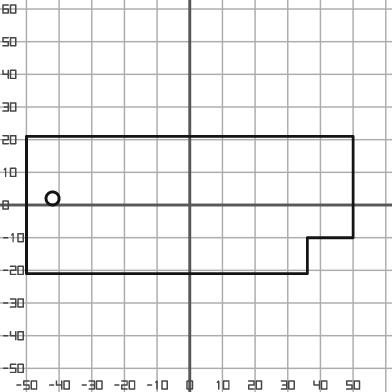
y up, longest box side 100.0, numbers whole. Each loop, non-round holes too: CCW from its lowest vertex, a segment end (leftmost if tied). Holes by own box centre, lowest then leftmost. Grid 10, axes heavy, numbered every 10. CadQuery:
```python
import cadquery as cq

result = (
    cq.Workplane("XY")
    .moveTo(-50.0, -21.0)
    .lineTo(36.0, -21.0)
    .lineTo(36.0, -10.0)
    .lineTo(50.0, -10.0)
    .lineTo(50.0, 21.0)
    .lineTo(-50.0, 21.0)
    .close()
    .moveTo(-42.0, 2.0)
    .circle(2.0)
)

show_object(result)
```